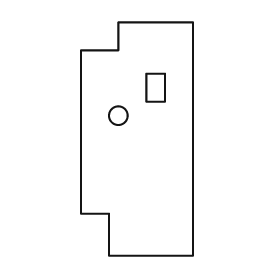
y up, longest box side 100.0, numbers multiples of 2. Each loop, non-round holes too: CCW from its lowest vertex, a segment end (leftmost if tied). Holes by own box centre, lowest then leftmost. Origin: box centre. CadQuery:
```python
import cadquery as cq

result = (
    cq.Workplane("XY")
    .moveTo(-12.0, -50.0)
    .lineTo(24.0, -50.0)
    .lineTo(24.0, 50.0)
    .lineTo(-8.0, 50.0)
    .lineTo(-8.0, 38.0)
    .lineTo(-24.0, 38.0)
    .lineTo(-24.0, -32.0)
    .lineTo(-12.0, -32.0)
    .close()
    .moveTo(-8.0, 10.0)
    .circle(4.0)
    .moveTo(4.0, 16.0)
    .lineTo(12.0, 16.0)
    .lineTo(12.0, 28.0)
    .lineTo(4.0, 28.0)
    .close()
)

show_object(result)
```